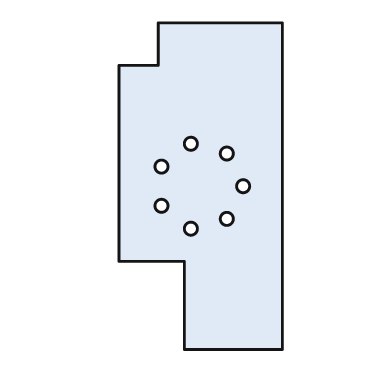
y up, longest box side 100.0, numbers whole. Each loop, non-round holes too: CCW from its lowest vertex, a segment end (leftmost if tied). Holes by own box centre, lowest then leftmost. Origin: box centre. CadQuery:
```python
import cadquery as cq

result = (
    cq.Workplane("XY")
    .moveTo(-5.0, -50.0)
    .lineTo(25.0, -50.0)
    .lineTo(25.0, 50.0)
    .lineTo(-13.0, 50.0)
    .lineTo(-13.0, 37.0)
    .lineTo(-25.0, 37.0)
    .lineTo(-25.0, -23.0)
    .lineTo(-5.0, -23.0)
    .close()
    .moveTo(-3.0, -13.0)
    .circle(2.0)
    .moveTo(8.0, -10.0)
    .circle(2.0)
    .moveTo(-12.0, -6.0)
    .circle(2.0)
    .moveTo(13.0, 0.0)
    .circle(2.0)
    .moveTo(-12.0, 6.0)
    .circle(2.0)
    .moveTo(8.0, 10.0)
    .circle(2.0)
    .moveTo(-3.0, 13.0)
    .circle(2.0)
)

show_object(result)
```